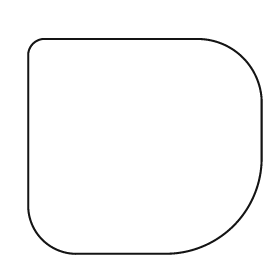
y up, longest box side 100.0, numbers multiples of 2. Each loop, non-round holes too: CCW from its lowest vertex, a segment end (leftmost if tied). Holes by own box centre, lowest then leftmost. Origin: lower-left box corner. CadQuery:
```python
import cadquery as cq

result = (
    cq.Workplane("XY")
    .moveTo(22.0, 0.0)
    .lineTo(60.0, 0.0)
    .threePointArc((88.0, 12.0), (100.0, 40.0))
    .lineTo(100.0, 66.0)
    .threePointArc((92.0, 84.0), (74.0, 92.0))
    .lineTo(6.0, 92.0)
    .threePointArc((2.0, 90.0), (0.0, 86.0))
    .lineTo(0.0, 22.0)
    .threePointArc((6.0, 6.0), (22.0, 0.0))
    .close()
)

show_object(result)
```